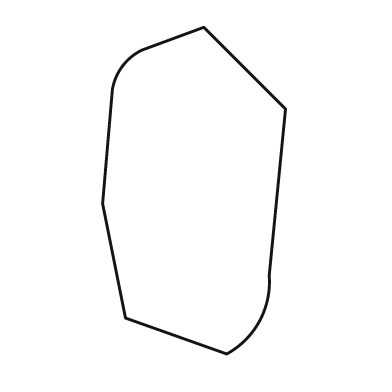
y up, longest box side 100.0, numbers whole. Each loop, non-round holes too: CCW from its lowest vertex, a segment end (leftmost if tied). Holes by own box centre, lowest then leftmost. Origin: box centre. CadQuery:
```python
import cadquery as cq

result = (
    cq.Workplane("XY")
    .moveTo(10.0, -50.0)
    .threePointArc((20.0, -40.0), (23.0, -26.0))
    .lineTo(28.0, 25.0)
    .lineTo(3.0, 50.0)
    .lineTo(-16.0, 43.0)
    .threePointArc((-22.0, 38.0), (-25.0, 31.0))
    .lineTo(-28.0, -4.0)
    .lineTo(-21.0, -39.0)
    .close()
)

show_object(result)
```